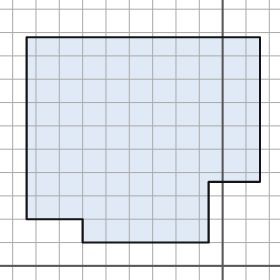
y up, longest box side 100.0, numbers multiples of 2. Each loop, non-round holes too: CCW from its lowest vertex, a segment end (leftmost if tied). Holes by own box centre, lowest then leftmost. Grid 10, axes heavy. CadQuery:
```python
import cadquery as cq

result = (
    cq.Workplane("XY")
    .moveTo(-60.0, 10.0)
    .lineTo(-6.0, 10.0)
    .lineTo(-6.0, 36.0)
    .lineTo(16.0, 36.0)
    .lineTo(16.0, 98.0)
    .lineTo(-84.0, 98.0)
    .lineTo(-84.0, 20.0)
    .lineTo(-60.0, 20.0)
    .close()
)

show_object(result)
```